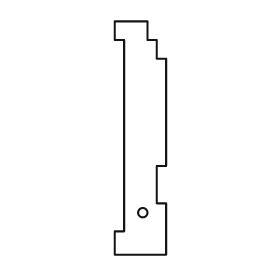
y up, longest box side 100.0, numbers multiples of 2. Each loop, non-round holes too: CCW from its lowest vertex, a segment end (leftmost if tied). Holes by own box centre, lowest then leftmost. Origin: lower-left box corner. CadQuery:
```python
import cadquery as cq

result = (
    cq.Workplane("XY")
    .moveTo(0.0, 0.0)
    .lineTo(22.0, 0.0)
    .lineTo(22.0, 22.0)
    .lineTo(18.0, 22.0)
    .lineTo(18.0, 38.0)
    .lineTo(22.0, 38.0)
    .lineTo(22.0, 84.0)
    .lineTo(18.0, 84.0)
    .lineTo(18.0, 92.0)
    .lineTo(14.0, 92.0)
    .lineTo(14.0, 100.0)
    .lineTo(0.0, 100.0)
    .lineTo(0.0, 92.0)
    .lineTo(4.0, 92.0)
    .lineTo(4.0, 10.0)
    .lineTo(0.0, 10.0)
    .close()
    .moveTo(12.0, 18.0)
    .circle(2.0)
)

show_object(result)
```